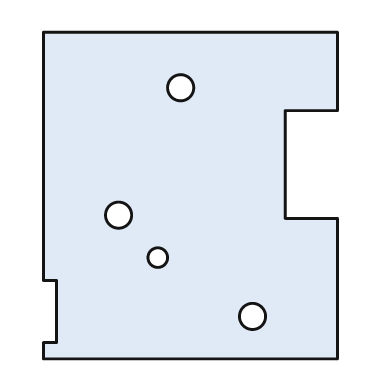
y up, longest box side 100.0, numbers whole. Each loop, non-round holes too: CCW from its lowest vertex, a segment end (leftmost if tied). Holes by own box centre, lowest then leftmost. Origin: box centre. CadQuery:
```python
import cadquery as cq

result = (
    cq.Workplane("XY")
    .moveTo(-45.0, -50.0)
    .lineTo(45.0, -50.0)
    .lineTo(45.0, -7.0)
    .lineTo(29.0, -7.0)
    .lineTo(29.0, 26.0)
    .lineTo(45.0, 26.0)
    .lineTo(45.0, 50.0)
    .lineTo(-45.0, 50.0)
    .lineTo(-45.0, -26.0)
    .lineTo(-41.0, -26.0)
    .lineTo(-41.0, -45.0)
    .lineTo(-45.0, -45.0)
    .close()
    .moveTo(19.0, -37.0)
    .circle(4.0)
    .moveTo(-10.0, -19.0)
    .circle(3.0)
    .moveTo(-22.0, -6.0)
    .circle(4.0)
    .moveTo(-3.0, 33.0)
    .circle(4.0)
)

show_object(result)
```